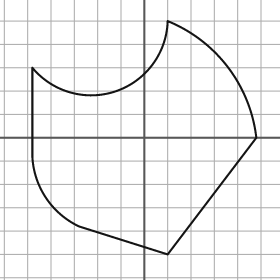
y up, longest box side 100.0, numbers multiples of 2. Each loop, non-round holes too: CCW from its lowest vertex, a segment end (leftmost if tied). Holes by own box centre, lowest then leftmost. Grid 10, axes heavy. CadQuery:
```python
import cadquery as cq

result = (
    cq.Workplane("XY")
    .moveTo(10.0, -50.0)
    .lineTo(48.0, 0.0)
    .threePointArc((36.0, 30.0), (10.0, 50.0))
    .threePointArc((-12.0, 20.0), (-48.0, 30.0))
    .lineTo(-48.0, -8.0)
    .threePointArc((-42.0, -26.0), (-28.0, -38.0))
    .close()
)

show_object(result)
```